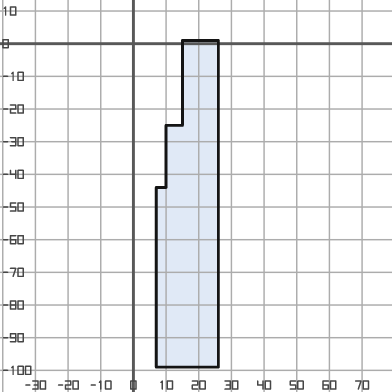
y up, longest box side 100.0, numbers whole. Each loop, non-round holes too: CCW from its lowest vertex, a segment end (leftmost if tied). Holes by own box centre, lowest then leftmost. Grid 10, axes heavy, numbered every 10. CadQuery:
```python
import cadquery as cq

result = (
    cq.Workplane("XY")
    .moveTo(7.0, -99.0)
    .lineTo(26.0, -99.0)
    .lineTo(26.0, 1.0)
    .lineTo(15.0, 1.0)
    .lineTo(15.0, -25.0)
    .lineTo(10.0, -25.0)
    .lineTo(10.0, -44.0)
    .lineTo(7.0, -44.0)
    .close()
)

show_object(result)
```